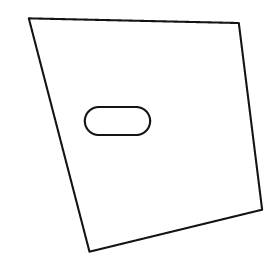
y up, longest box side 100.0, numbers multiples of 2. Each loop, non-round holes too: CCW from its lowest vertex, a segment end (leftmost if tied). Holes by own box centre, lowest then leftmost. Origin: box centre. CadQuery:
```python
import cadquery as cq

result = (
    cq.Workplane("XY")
    .moveTo(-24.0, -50.0)
    .lineTo(50.0, -32.0)
    .lineTo(40.0, 48.0)
    .lineTo(-50.0, 50.0)
    .close()
    .moveTo(-20.0, 0.0)
    .lineTo(-4.0, 0.0)
    .threePointArc((2.0, 6.0), (-4.0, 12.0))
    .lineTo(-20.0, 12.0)
    .threePointArc((-26.0, 6.0), (-20.0, 0.0))
    .close()
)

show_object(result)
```